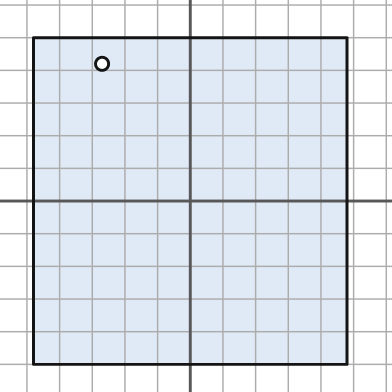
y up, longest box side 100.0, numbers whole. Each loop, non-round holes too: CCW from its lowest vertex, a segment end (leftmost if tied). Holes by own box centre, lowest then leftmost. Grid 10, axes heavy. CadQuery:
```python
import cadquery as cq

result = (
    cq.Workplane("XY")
    .moveTo(-48.0, -50.0)
    .lineTo(48.0, -50.0)
    .lineTo(48.0, 50.0)
    .lineTo(-48.0, 50.0)
    .close()
    .moveTo(-27.0, 42.0)
    .circle(2.0)
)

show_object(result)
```